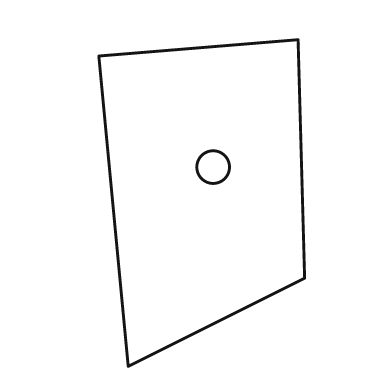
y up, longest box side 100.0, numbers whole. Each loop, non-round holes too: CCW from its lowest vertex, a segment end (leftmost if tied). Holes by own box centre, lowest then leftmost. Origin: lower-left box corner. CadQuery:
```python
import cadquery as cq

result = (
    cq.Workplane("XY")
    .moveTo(9.0, 0.0)
    .lineTo(63.0, 27.0)
    .lineTo(61.0, 100.0)
    .lineTo(0.0, 95.0)
    .close()
    .moveTo(35.0, 61.0)
    .circle(5.0)
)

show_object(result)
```